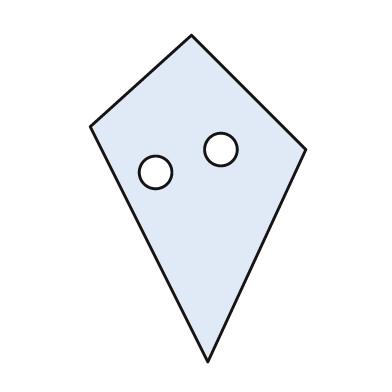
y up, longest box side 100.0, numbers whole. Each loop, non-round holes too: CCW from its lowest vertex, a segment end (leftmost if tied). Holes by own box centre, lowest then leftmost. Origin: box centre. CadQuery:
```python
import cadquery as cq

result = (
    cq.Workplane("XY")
    .moveTo(3.0, -50.0)
    .lineTo(33.0, 15.0)
    .lineTo(-2.0, 50.0)
    .lineTo(-33.0, 22.0)
    .close()
    .moveTo(-13.0, 8.0)
    .circle(5.0)
    .moveTo(7.0, 15.0)
    .circle(5.0)
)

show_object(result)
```